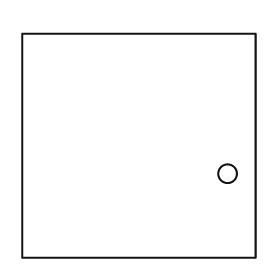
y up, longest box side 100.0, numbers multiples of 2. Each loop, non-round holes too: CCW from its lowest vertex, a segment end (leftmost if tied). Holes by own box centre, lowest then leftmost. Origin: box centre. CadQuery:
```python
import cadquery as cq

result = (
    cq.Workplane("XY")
    .moveTo(-50.0, -48.0)
    .lineTo(50.0, -48.0)
    .lineTo(50.0, 48.0)
    .lineTo(-50.0, 48.0)
    .close()
    .moveTo(38.0, -12.0)
    .circle(4.0)
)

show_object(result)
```